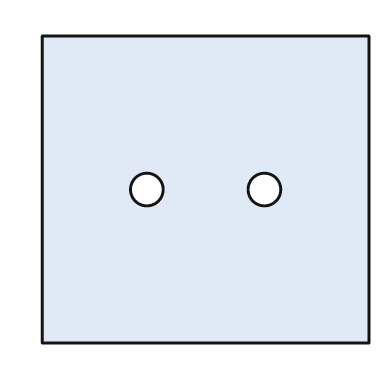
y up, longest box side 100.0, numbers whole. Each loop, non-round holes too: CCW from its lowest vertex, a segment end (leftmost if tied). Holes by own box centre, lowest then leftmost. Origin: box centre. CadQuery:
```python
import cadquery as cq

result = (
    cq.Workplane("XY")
    .moveTo(-50.0, -47.0)
    .lineTo(50.0, -47.0)
    .lineTo(50.0, 47.0)
    .lineTo(-50.0, 47.0)
    .close()
    .moveTo(-18.0, 0.0)
    .circle(5.0)
    .moveTo(18.0, 0.0)
    .circle(5.0)
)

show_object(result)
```